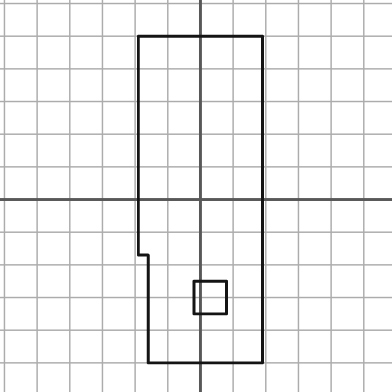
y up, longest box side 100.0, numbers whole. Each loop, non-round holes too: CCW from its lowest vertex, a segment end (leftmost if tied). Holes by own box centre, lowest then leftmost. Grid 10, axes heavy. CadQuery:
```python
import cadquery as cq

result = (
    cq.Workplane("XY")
    .moveTo(-16.0, -50.0)
    .lineTo(19.0, -50.0)
    .lineTo(19.0, 50.0)
    .lineTo(-19.0, 50.0)
    .lineTo(-19.0, -17.0)
    .lineTo(-16.0, -17.0)
    .close()
    .moveTo(-2.0, -35.0)
    .lineTo(8.0, -35.0)
    .lineTo(8.0, -25.0)
    .lineTo(-2.0, -25.0)
    .close()
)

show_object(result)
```